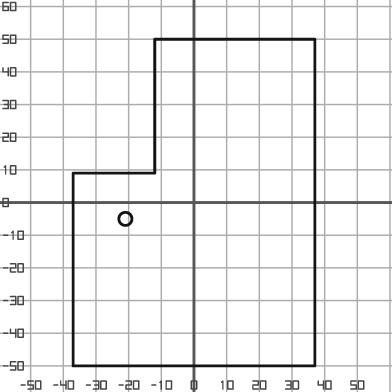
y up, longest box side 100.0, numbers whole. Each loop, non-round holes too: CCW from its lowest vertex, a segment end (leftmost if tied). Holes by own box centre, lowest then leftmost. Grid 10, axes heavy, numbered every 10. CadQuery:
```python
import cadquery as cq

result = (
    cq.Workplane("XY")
    .moveTo(-37.0, -50.0)
    .lineTo(37.0, -50.0)
    .lineTo(37.0, 50.0)
    .lineTo(-12.0, 50.0)
    .lineTo(-12.0, 9.0)
    .lineTo(-37.0, 9.0)
    .close()
    .moveTo(-21.0, -5.0)
    .circle(2.0)
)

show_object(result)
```